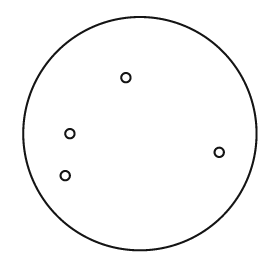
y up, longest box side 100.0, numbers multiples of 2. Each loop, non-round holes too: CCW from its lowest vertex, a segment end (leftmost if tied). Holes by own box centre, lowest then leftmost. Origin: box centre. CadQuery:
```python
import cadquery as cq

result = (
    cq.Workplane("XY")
    .moveTo(0.0, 0.0)
    .circle(50.0)
    .moveTo(-32.0, -18.0)
    .circle(2.0)
    .moveTo(34.0, -8.0)
    .circle(2.0)
    .moveTo(-30.0, 0.0)
    .circle(2.0)
    .moveTo(-6.0, 24.0)
    .circle(2.0)
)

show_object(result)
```